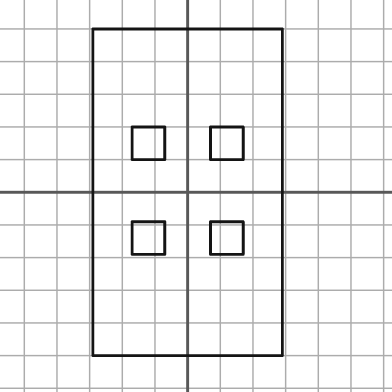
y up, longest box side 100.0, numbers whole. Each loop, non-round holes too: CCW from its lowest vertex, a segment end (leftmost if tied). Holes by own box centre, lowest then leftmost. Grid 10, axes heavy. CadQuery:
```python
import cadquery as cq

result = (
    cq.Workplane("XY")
    .moveTo(-29.0, -50.0)
    .lineTo(29.0, -50.0)
    .lineTo(29.0, 50.0)
    .lineTo(-29.0, 50.0)
    .close()
    .moveTo(-17.0, -19.0)
    .lineTo(-7.0, -19.0)
    .lineTo(-7.0, -9.0)
    .lineTo(-17.0, -9.0)
    .close()
    .moveTo(7.0, -19.0)
    .lineTo(17.0, -19.0)
    .lineTo(17.0, -9.0)
    .lineTo(7.0, -9.0)
    .close()
    .moveTo(-17.0, 10.0)
    .lineTo(-7.0, 10.0)
    .lineTo(-7.0, 20.0)
    .lineTo(-17.0, 20.0)
    .close()
    .moveTo(7.0, 10.0)
    .lineTo(17.0, 10.0)
    .lineTo(17.0, 20.0)
    .lineTo(7.0, 20.0)
    .close()
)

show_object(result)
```